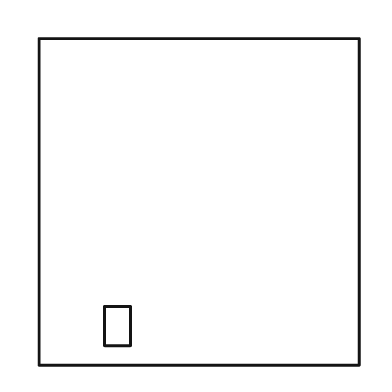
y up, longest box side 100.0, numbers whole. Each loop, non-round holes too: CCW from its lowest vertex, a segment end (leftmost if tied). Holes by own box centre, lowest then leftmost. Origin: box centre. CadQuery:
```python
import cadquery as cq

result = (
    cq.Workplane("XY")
    .moveTo(-49.0, -50.0)
    .lineTo(49.0, -50.0)
    .lineTo(49.0, 50.0)
    .lineTo(-49.0, 50.0)
    .close()
    .moveTo(-29.0, -44.0)
    .lineTo(-21.0, -44.0)
    .lineTo(-21.0, -32.0)
    .lineTo(-29.0, -32.0)
    .close()
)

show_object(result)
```